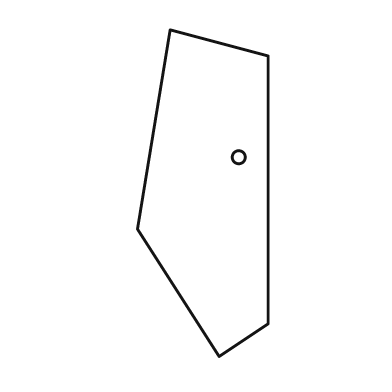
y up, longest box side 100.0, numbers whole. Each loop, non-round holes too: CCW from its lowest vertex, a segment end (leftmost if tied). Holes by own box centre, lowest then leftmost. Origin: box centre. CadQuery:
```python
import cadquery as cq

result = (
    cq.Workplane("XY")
    .moveTo(5.0, -50.0)
    .lineTo(20.0, -40.0)
    .lineTo(20.0, 42.0)
    .lineTo(-10.0, 50.0)
    .lineTo(-20.0, -11.0)
    .close()
    .moveTo(11.0, 11.0)
    .circle(2.0)
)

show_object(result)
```